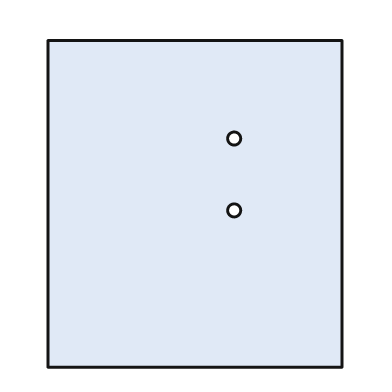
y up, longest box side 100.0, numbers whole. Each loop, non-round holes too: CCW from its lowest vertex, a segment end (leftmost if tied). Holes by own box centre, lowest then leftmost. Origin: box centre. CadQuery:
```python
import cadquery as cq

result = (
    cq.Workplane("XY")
    .moveTo(-45.0, -50.0)
    .lineTo(45.0, -50.0)
    .lineTo(45.0, 50.0)
    .lineTo(-45.0, 50.0)
    .close()
    .moveTo(12.0, -2.0)
    .circle(2.0)
    .moveTo(12.0, 20.0)
    .circle(2.0)
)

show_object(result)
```